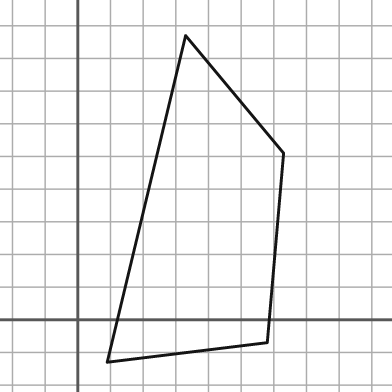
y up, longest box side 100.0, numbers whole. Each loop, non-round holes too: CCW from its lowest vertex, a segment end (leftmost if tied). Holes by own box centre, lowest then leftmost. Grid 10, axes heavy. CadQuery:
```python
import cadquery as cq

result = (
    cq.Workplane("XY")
    .moveTo(9.0, -13.0)
    .lineTo(58.0, -7.0)
    .lineTo(63.0, 51.0)
    .lineTo(33.0, 87.0)
    .close()
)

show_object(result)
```